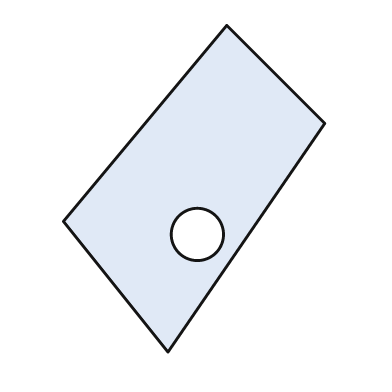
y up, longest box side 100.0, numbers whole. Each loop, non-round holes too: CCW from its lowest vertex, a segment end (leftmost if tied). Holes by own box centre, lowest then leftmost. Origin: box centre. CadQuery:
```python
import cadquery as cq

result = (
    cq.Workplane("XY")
    .moveTo(-8.0, -50.0)
    .lineTo(40.0, 20.0)
    .lineTo(10.0, 50.0)
    .lineTo(-40.0, -10.0)
    .close()
    .moveTo(1.0, -14.0)
    .circle(8.0)
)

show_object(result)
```